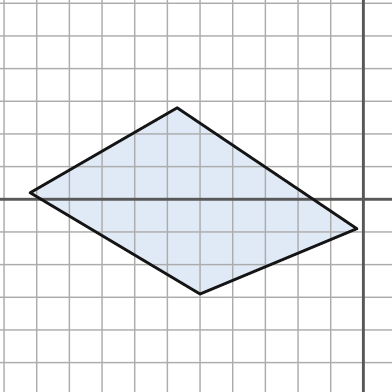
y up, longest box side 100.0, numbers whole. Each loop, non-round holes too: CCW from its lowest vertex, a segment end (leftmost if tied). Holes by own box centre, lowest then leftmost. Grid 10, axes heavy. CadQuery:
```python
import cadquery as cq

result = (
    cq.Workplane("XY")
    .moveTo(-50.0, -29.0)
    .lineTo(-2.0, -9.0)
    .lineTo(-57.0, 28.0)
    .lineTo(-102.0, 2.0)
    .close()
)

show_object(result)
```